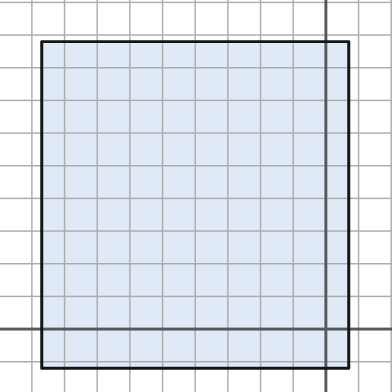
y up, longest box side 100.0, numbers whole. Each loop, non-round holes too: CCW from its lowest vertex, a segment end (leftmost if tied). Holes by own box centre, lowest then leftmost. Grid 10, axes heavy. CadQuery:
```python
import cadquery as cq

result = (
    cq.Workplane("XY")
    .moveTo(-87.0, -12.0)
    .lineTo(7.0, -12.0)
    .lineTo(7.0, 88.0)
    .lineTo(-87.0, 88.0)
    .close()
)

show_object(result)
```